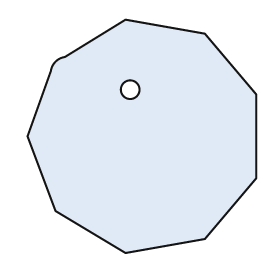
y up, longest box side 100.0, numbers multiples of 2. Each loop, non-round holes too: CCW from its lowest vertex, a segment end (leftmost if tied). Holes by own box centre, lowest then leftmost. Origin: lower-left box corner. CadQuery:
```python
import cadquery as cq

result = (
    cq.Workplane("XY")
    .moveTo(42.0, 0.0)
    .lineTo(76.0, 6.0)
    .lineTo(98.0, 32.0)
    .lineTo(98.0, 68.0)
    .lineTo(76.0, 94.0)
    .lineTo(42.0, 100.0)
    .lineTo(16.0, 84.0)
    .threePointArc((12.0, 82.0), (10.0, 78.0))
    .lineTo(0.0, 50.0)
    .lineTo(12.0, 18.0)
    .close()
    .moveTo(44.0, 70.0)
    .circle(4.0)
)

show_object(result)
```